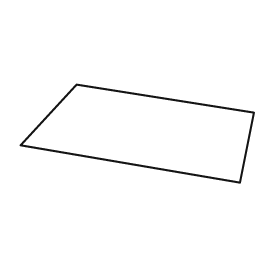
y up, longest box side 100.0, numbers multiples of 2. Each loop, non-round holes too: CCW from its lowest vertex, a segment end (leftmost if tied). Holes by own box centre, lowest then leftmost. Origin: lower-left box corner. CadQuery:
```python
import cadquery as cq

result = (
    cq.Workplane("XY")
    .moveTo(94.0, 0.0)
    .lineTo(100.0, 30.0)
    .lineTo(24.0, 42.0)
    .lineTo(0.0, 16.0)
    .close()
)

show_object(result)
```